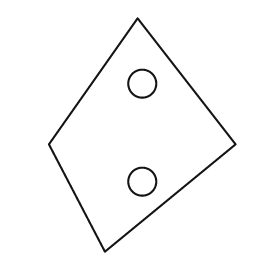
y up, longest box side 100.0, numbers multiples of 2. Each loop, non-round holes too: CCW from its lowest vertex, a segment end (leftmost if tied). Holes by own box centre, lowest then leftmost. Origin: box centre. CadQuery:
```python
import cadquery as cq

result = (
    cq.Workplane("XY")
    .moveTo(-16.0, -50.0)
    .lineTo(40.0, -4.0)
    .lineTo(-2.0, 50.0)
    .lineTo(-40.0, -4.0)
    .close()
    .moveTo(0.0, -20.0)
    .circle(6.0)
    .moveTo(0.0, 22.0)
    .circle(6.0)
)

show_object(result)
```